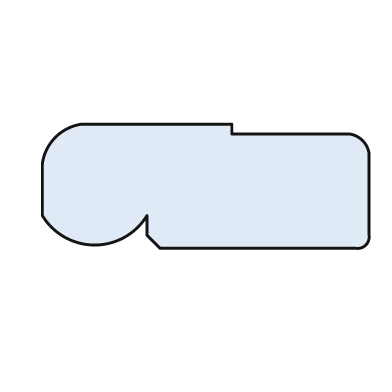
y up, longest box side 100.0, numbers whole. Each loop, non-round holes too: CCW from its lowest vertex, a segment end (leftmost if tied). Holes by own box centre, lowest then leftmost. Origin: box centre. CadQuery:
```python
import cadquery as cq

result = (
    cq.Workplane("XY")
    .moveTo(-14.0, -19.0)
    .lineTo(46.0, -19.0)
    .threePointArc((49.0, -18.0), (50.0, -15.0))
    .lineTo(50.0, 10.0)
    .threePointArc((48.0, 14.0), (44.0, 16.0))
    .lineTo(8.0, 16.0)
    .lineTo(8.0, 19.0)
    .lineTo(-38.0, 19.0)
    .threePointArc((-46.0, 15.0), (-50.0, 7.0))
    .lineTo(-50.0, -9.0)
    .threePointArc((-34.0, -18.0), (-18.0, -9.0))
    .lineTo(-18.0, -15.0)
    .close()
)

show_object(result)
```